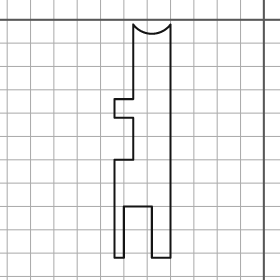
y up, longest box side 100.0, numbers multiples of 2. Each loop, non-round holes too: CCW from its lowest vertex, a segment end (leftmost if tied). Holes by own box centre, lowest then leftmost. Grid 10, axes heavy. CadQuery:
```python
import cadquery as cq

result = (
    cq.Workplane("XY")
    .moveTo(-64.0, -102.0)
    .lineTo(-60.0, -102.0)
    .lineTo(-60.0, -80.0)
    .lineTo(-48.0, -80.0)
    .lineTo(-48.0, -102.0)
    .lineTo(-40.0, -102.0)
    .lineTo(-40.0, -2.0)
    .threePointArc((-48.0, -6.0), (-56.0, -2.0))
    .lineTo(-56.0, -34.0)
    .lineTo(-64.0, -34.0)
    .lineTo(-64.0, -42.0)
    .lineTo(-56.0, -42.0)
    .lineTo(-56.0, -60.0)
    .lineTo(-64.0, -60.0)
    .close()
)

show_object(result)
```